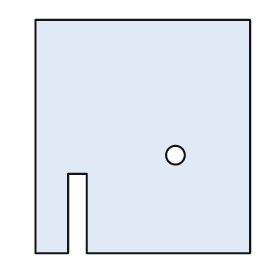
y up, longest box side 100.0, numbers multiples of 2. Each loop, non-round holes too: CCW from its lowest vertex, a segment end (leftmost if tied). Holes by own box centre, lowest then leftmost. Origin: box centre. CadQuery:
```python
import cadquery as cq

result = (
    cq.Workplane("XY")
    .moveTo(-46.0, -50.0)
    .lineTo(-32.0, -50.0)
    .lineTo(-32.0, -16.0)
    .lineTo(-24.0, -16.0)
    .lineTo(-24.0, -50.0)
    .lineTo(46.0, -50.0)
    .lineTo(46.0, 50.0)
    .lineTo(-46.0, 50.0)
    .close()
    .moveTo(14.0, -8.0)
    .circle(4.0)
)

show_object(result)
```